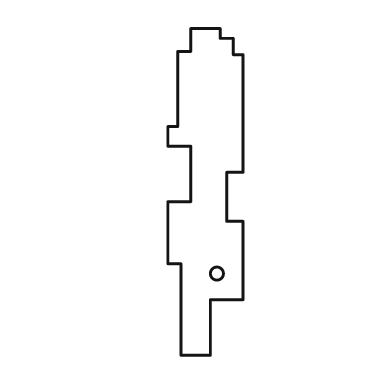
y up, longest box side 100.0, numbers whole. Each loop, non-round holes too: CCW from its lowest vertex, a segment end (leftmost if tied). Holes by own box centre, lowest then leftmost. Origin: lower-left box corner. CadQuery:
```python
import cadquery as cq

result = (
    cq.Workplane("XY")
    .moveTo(4.0, 0.0)
    .lineTo(13.0, 0.0)
    .lineTo(13.0, 17.0)
    .lineTo(23.0, 17.0)
    .lineTo(23.0, 41.0)
    .lineTo(18.0, 41.0)
    .lineTo(18.0, 56.0)
    .lineTo(23.0, 56.0)
    .lineTo(23.0, 92.0)
    .lineTo(20.0, 92.0)
    .lineTo(20.0, 97.0)
    .lineTo(16.0, 97.0)
    .lineTo(16.0, 100.0)
    .lineTo(7.0, 100.0)
    .lineTo(7.0, 93.0)
    .lineTo(3.0, 93.0)
    .lineTo(3.0, 70.0)
    .lineTo(0.0, 70.0)
    .lineTo(0.0, 64.0)
    .lineTo(7.0, 64.0)
    .lineTo(7.0, 47.0)
    .lineTo(0.0, 47.0)
    .lineTo(0.0, 28.0)
    .lineTo(4.0, 28.0)
    .close()
    .moveTo(15.0, 25.0)
    .circle(2.0)
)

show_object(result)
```